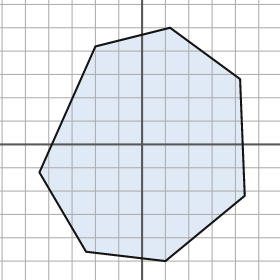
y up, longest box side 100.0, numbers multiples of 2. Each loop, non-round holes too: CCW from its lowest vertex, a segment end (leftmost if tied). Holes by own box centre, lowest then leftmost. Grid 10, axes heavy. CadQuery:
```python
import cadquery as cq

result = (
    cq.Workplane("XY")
    .moveTo(10.0, -50.0)
    .lineTo(44.0, -22.0)
    .lineTo(42.0, 28.0)
    .lineTo(12.0, 50.0)
    .lineTo(-20.0, 42.0)
    .lineTo(-44.0, -12.0)
    .lineTo(-24.0, -46.0)
    .close()
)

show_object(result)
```